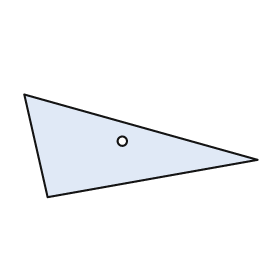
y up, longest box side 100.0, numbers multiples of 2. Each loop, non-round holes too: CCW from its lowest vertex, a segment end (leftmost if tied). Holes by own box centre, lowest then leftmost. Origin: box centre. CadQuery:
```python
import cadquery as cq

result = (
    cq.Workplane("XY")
    .moveTo(-40.0, -22.0)
    .lineTo(50.0, -6.0)
    .lineTo(-50.0, 22.0)
    .close()
    .moveTo(-8.0, 2.0)
    .circle(2.0)
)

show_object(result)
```